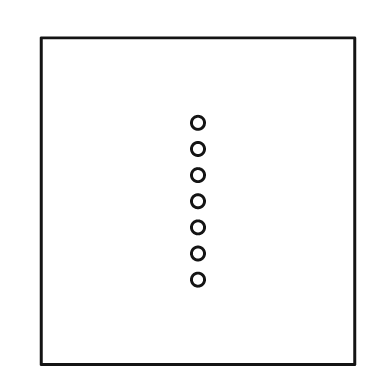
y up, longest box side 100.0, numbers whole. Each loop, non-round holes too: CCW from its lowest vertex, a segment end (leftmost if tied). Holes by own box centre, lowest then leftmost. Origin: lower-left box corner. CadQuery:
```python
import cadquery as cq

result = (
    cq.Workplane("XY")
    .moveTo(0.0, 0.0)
    .lineTo(96.0, 0.0)
    .lineTo(96.0, 100.0)
    .lineTo(0.0, 100.0)
    .close()
    .moveTo(48.0, 26.0)
    .circle(2.0)
    .moveTo(48.0, 34.0)
    .circle(2.0)
    .moveTo(48.0, 42.0)
    .circle(2.0)
    .moveTo(48.0, 50.0)
    .circle(2.0)
    .moveTo(48.0, 58.0)
    .circle(2.0)
    .moveTo(48.0, 66.0)
    .circle(2.0)
    .moveTo(48.0, 74.0)
    .circle(2.0)
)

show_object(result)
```